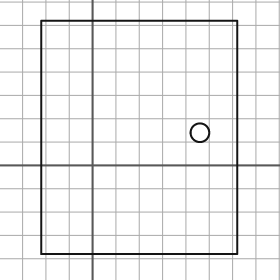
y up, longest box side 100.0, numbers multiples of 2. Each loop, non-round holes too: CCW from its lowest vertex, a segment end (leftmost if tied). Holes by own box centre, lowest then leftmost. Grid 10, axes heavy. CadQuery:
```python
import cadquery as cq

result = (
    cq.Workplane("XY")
    .moveTo(-22.0, -38.0)
    .lineTo(62.0, -38.0)
    .lineTo(62.0, 62.0)
    .lineTo(-22.0, 62.0)
    .close()
    .moveTo(46.0, 14.0)
    .circle(4.0)
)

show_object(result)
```